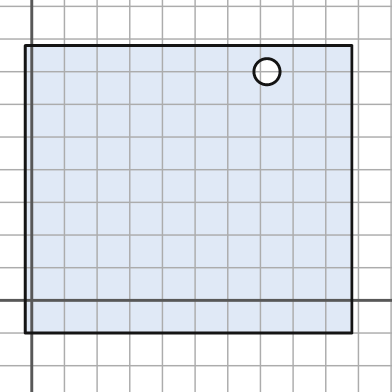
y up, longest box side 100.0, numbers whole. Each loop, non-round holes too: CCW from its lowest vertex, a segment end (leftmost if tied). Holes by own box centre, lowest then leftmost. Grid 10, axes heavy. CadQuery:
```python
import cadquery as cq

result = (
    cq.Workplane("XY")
    .moveTo(-2.0, -10.0)
    .lineTo(98.0, -10.0)
    .lineTo(98.0, 78.0)
    .lineTo(-2.0, 78.0)
    .close()
    .moveTo(72.0, 70.0)
    .circle(4.0)
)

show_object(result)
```